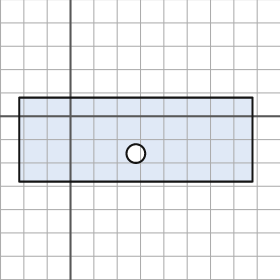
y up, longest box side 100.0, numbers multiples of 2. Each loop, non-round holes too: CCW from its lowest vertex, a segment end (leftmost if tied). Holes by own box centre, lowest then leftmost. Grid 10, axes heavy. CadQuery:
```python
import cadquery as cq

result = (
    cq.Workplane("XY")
    .moveTo(-22.0, -28.0)
    .lineTo(78.0, -28.0)
    .lineTo(78.0, 8.0)
    .lineTo(-22.0, 8.0)
    .close()
    .moveTo(28.0, -16.0)
    .circle(4.0)
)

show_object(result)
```